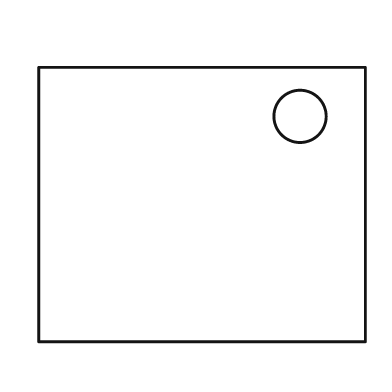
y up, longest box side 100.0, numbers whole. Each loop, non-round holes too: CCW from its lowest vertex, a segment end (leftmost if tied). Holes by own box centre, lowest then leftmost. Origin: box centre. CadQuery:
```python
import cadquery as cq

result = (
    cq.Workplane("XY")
    .moveTo(-50.0, -42.0)
    .lineTo(50.0, -42.0)
    .lineTo(50.0, 42.0)
    .lineTo(-50.0, 42.0)
    .close()
    .moveTo(30.0, 27.0)
    .circle(8.0)
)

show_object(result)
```